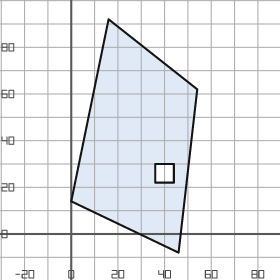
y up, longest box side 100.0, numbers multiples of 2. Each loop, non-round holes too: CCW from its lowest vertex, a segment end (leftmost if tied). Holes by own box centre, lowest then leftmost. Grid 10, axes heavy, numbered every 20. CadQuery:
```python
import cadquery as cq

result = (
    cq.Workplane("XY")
    .moveTo(46.0, -8.0)
    .lineTo(54.0, 62.0)
    .lineTo(16.0, 92.0)
    .lineTo(0.0, 14.0)
    .close()
    .moveTo(36.0, 22.0)
    .lineTo(44.0, 22.0)
    .lineTo(44.0, 30.0)
    .lineTo(36.0, 30.0)
    .close()
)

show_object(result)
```